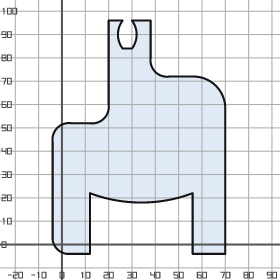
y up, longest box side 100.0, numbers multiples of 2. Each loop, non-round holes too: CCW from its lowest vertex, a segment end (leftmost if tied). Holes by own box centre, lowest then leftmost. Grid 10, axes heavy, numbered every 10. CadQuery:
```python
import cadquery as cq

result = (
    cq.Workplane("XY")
    .moveTo(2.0, -4.0)
    .lineTo(12.0, -4.0)
    .lineTo(12.0, 22.0)
    .threePointArc((34.0, 18.0), (56.0, 22.0))
    .lineTo(56.0, -4.0)
    .lineTo(70.0, -4.0)
    .lineTo(70.0, 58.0)
    .threePointArc((66.0, 68.0), (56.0, 72.0))
    .lineTo(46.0, 72.0)
    .threePointArc((40.0, 74.0), (38.0, 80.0))
    .lineTo(38.0, 96.0)
    .lineTo(30.0, 96.0)
    .threePointArc((32.0, 90.0), (30.0, 84.0))
    .lineTo(26.0, 84.0)
    .threePointArc((24.0, 90.0), (26.0, 96.0))
    .lineTo(20.0, 96.0)
    .lineTo(20.0, 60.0)
    .threePointArc((18.0, 54.0), (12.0, 52.0))
    .lineTo(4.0, 52.0)
    .threePointArc((-2.0, 50.0), (-4.0, 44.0))
    .lineTo(-4.0, 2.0)
    .threePointArc((-2.0, -2.0), (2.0, -4.0))
    .close()
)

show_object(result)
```